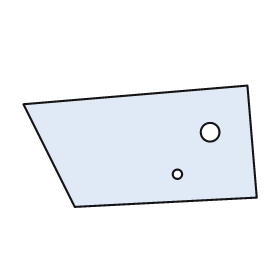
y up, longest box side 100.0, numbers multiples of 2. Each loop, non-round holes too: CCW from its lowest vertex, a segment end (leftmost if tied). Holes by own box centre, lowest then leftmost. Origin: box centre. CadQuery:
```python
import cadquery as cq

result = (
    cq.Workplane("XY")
    .moveTo(-28.0, -26.0)
    .lineTo(50.0, -22.0)
    .lineTo(46.0, 26.0)
    .lineTo(-50.0, 18.0)
    .close()
    .moveTo(16.0, -12.0)
    .circle(2.0)
    .moveTo(30.0, 6.0)
    .circle(4.0)
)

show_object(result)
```